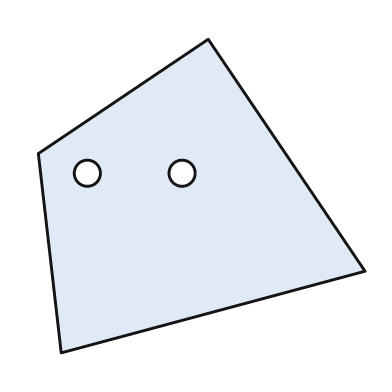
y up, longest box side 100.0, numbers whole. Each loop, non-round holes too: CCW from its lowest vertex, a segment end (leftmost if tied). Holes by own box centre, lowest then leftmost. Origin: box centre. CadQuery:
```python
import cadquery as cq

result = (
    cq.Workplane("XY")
    .moveTo(-43.0, -48.0)
    .lineTo(50.0, -23.0)
    .lineTo(2.0, 48.0)
    .lineTo(-50.0, 13.0)
    .close()
    .moveTo(-35.0, 7.0)
    .circle(4.0)
    .moveTo(-6.0, 7.0)
    .circle(4.0)
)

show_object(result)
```